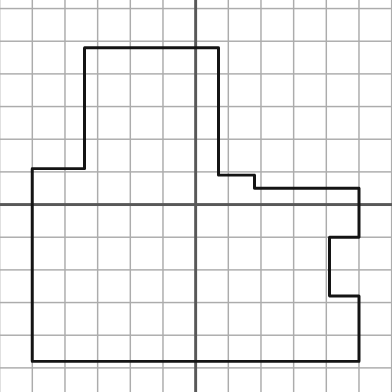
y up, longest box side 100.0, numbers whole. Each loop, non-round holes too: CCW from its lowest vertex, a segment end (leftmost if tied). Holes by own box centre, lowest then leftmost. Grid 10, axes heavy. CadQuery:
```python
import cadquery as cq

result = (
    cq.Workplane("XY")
    .moveTo(-50.0, -48.0)
    .lineTo(50.0, -48.0)
    .lineTo(50.0, -28.0)
    .lineTo(41.0, -28.0)
    .lineTo(41.0, -10.0)
    .lineTo(50.0, -10.0)
    .lineTo(50.0, 5.0)
    .lineTo(18.0, 5.0)
    .lineTo(18.0, 9.0)
    .lineTo(7.0, 9.0)
    .lineTo(7.0, 48.0)
    .lineTo(-34.0, 48.0)
    .lineTo(-34.0, 11.0)
    .lineTo(-50.0, 11.0)
    .close()
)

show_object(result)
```